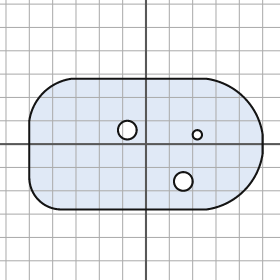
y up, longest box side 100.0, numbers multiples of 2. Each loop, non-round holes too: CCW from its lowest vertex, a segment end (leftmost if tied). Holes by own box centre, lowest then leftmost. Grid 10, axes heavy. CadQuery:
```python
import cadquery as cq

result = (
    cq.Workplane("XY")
    .moveTo(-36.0, -28.0)
    .lineTo(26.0, -28.0)
    .threePointArc((42.0, -20.0), (50.0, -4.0))
    .lineTo(50.0, 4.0)
    .threePointArc((42.0, 20.0), (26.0, 28.0))
    .lineTo(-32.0, 28.0)
    .threePointArc((-44.0, 22.0), (-50.0, 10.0))
    .lineTo(-50.0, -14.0)
    .threePointArc((-46.0, -24.0), (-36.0, -28.0))
    .close()
    .moveTo(16.0, -16.0)
    .circle(4.0)
    .moveTo(22.0, 4.0)
    .circle(2.0)
    .moveTo(-8.0, 6.0)
    .circle(4.0)
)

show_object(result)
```